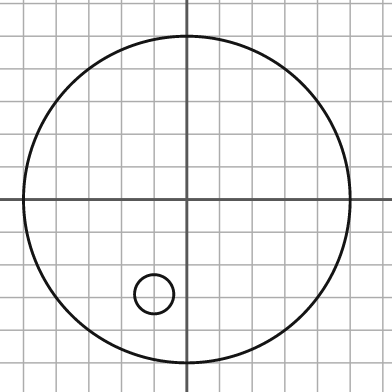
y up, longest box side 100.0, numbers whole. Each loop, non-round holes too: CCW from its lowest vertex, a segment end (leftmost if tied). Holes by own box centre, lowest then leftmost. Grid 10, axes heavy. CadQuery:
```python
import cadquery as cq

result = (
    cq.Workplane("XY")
    .moveTo(0.0, 0.0)
    .circle(50.0)
    .moveTo(-10.0, -29.0)
    .circle(6.0)
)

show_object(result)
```